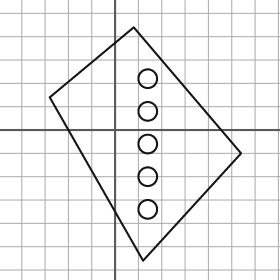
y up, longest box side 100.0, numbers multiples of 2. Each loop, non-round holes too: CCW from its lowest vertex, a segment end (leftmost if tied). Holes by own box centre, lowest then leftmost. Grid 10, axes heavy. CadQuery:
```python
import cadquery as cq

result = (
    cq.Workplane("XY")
    .moveTo(12.0, -56.0)
    .lineTo(54.0, -10.0)
    .lineTo(8.0, 44.0)
    .lineTo(-28.0, 14.0)
    .close()
    .moveTo(14.0, -34.0)
    .circle(4.0)
    .moveTo(14.0, -20.0)
    .circle(4.0)
    .moveTo(14.0, -6.0)
    .circle(4.0)
    .moveTo(14.0, 8.0)
    .circle(4.0)
    .moveTo(14.0, 22.0)
    .circle(4.0)
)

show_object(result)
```